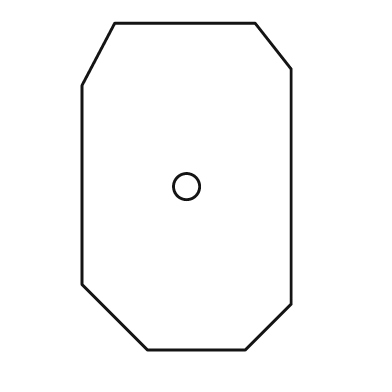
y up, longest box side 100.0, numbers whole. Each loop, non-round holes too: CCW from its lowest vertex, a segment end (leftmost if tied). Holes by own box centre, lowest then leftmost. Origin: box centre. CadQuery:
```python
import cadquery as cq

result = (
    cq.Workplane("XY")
    .moveTo(-12.0, -50.0)
    .lineTo(18.0, -50.0)
    .lineTo(32.0, -36.0)
    .lineTo(32.0, 36.0)
    .lineTo(21.0, 50.0)
    .lineTo(-22.0, 50.0)
    .lineTo(-32.0, 31.0)
    .lineTo(-32.0, -30.0)
    .close()
    .moveTo(0.0, 0.0)
    .circle(4.0)
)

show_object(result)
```